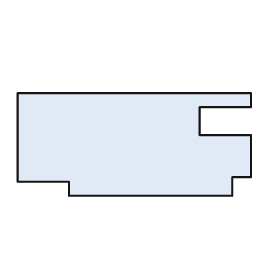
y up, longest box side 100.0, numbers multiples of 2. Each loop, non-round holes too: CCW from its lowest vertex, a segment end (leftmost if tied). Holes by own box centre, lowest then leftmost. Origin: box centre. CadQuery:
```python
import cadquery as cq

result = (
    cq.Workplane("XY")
    .moveTo(-28.0, -22.0)
    .lineTo(42.0, -22.0)
    .lineTo(42.0, -14.0)
    .lineTo(50.0, -14.0)
    .lineTo(50.0, 4.0)
    .lineTo(28.0, 4.0)
    .lineTo(28.0, 16.0)
    .lineTo(50.0, 16.0)
    .lineTo(50.0, 22.0)
    .lineTo(-50.0, 22.0)
    .lineTo(-50.0, -16.0)
    .lineTo(-28.0, -16.0)
    .close()
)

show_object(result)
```